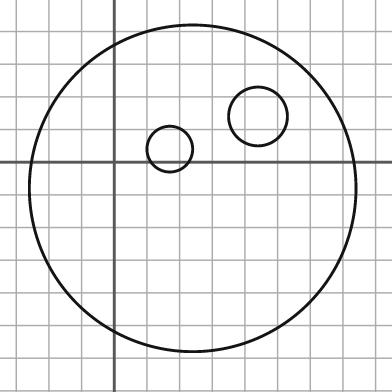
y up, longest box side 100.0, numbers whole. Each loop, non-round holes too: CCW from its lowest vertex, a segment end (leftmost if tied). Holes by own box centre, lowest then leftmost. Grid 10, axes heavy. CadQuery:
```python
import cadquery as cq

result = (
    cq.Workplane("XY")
    .moveTo(24.0, -8.0)
    .circle(50.0)
    .moveTo(17.0, 4.0)
    .circle(7.0)
    .moveTo(44.0, 14.0)
    .circle(9.0)
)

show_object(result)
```